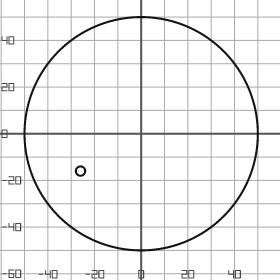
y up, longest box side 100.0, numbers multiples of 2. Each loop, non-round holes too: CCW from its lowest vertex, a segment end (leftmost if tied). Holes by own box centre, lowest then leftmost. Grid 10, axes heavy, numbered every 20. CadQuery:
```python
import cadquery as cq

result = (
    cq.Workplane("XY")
    .moveTo(0.0, 0.0)
    .circle(50.0)
    .moveTo(-26.0, -16.0)
    .circle(2.0)
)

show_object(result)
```